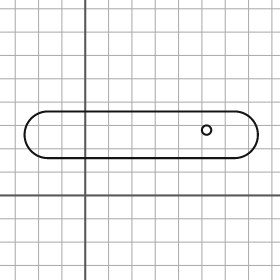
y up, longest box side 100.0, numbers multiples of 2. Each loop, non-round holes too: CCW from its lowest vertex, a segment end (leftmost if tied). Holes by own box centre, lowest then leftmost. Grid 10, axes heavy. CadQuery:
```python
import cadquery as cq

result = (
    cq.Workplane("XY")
    .moveTo(-16.0, 16.0)
    .lineTo(64.0, 16.0)
    .threePointArc((74.0, 26.0), (64.0, 36.0))
    .lineTo(-16.0, 36.0)
    .threePointArc((-26.0, 26.0), (-16.0, 16.0))
    .close()
    .moveTo(52.0, 28.0)
    .circle(2.0)
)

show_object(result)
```